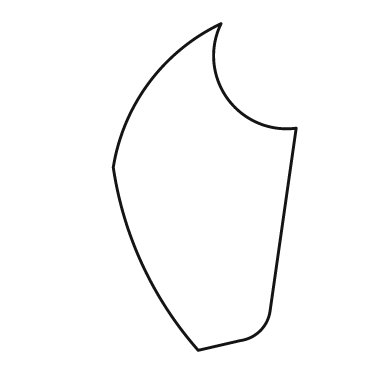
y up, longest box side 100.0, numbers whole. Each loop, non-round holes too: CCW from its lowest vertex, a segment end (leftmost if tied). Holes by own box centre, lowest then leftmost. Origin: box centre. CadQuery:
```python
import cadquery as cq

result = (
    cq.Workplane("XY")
    .moveTo(-2.0, -50.0)
    .lineTo(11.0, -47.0)
    .threePointArc((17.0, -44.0), (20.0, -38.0))
    .lineTo(28.0, 18.0)
    .threePointArc((7.0, 27.0), (5.0, 50.0))
    .threePointArc((-17.0, 32.0), (-28.0, 6.0))
    .threePointArc((-19.0, -24.0), (-2.0, -50.0))
    .close()
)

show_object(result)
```